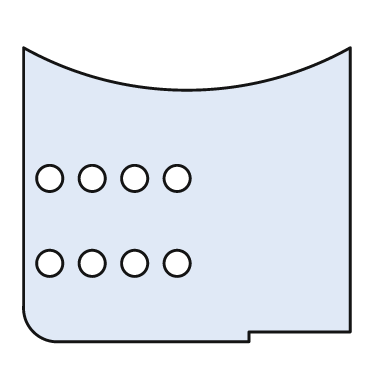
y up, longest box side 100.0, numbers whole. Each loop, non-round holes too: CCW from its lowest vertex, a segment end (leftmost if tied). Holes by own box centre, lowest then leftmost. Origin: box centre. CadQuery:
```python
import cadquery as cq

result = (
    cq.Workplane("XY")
    .moveTo(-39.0, -45.0)
    .lineTo(19.0, -45.0)
    .lineTo(19.0, -42.0)
    .lineTo(50.0, -42.0)
    .lineTo(50.0, 45.0)
    .threePointArc((0.0, 32.0), (-50.0, 45.0))
    .lineTo(-50.0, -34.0)
    .threePointArc((-47.0, -42.0), (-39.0, -45.0))
    .close()
    .moveTo(-42.0, -21.0)
    .circle(4.0)
    .moveTo(-29.0, -21.0)
    .circle(4.0)
    .moveTo(-16.0, -21.0)
    .circle(4.0)
    .moveTo(-3.0, -21.0)
    .circle(4.0)
    .moveTo(-42.0, 5.0)
    .circle(4.0)
    .moveTo(-29.0, 5.0)
    .circle(4.0)
    .moveTo(-16.0, 5.0)
    .circle(4.0)
    .moveTo(-3.0, 5.0)
    .circle(4.0)
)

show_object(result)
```